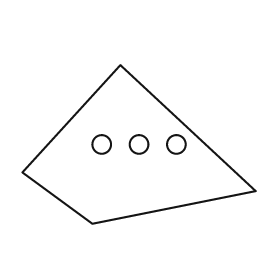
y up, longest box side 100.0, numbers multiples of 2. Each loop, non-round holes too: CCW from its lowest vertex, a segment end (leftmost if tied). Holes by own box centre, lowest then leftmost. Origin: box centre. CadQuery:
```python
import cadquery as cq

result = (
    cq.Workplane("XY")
    .moveTo(-20.0, -34.0)
    .lineTo(50.0, -20.0)
    .lineTo(-8.0, 34.0)
    .lineTo(-50.0, -12.0)
    .close()
    .moveTo(-16.0, 0.0)
    .circle(4.0)
    .moveTo(0.0, 0.0)
    .circle(4.0)
    .moveTo(16.0, 0.0)
    .circle(4.0)
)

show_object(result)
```